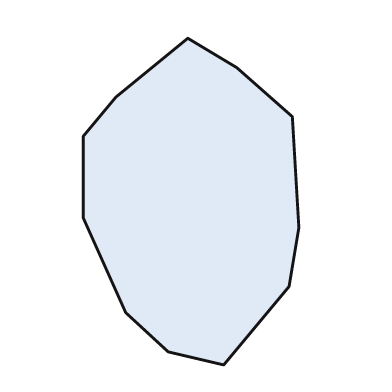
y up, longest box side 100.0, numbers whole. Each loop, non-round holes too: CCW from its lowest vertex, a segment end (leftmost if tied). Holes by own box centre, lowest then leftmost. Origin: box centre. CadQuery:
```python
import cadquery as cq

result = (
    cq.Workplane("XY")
    .moveTo(10.0, -50.0)
    .lineTo(30.0, -26.0)
    .lineTo(33.0, -8.0)
    .lineTo(31.0, 26.0)
    .lineTo(14.0, 41.0)
    .lineTo(-1.0, 50.0)
    .lineTo(-23.0, 32.0)
    .lineTo(-33.0, 20.0)
    .lineTo(-33.0, -5.0)
    .lineTo(-20.0, -34.0)
    .lineTo(-7.0, -46.0)
    .close()
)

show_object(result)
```